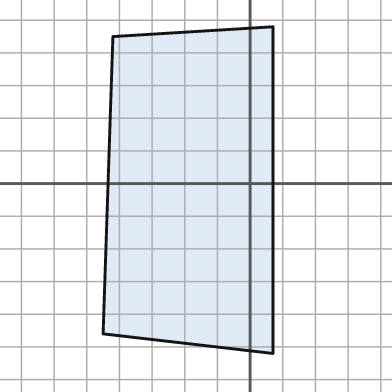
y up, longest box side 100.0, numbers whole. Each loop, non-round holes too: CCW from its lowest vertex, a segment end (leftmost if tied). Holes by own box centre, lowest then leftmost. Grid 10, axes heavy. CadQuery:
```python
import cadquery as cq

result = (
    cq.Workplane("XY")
    .moveTo(7.0, -52.0)
    .lineTo(7.0, 48.0)
    .lineTo(-42.0, 45.0)
    .lineTo(-45.0, -46.0)
    .close()
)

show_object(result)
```